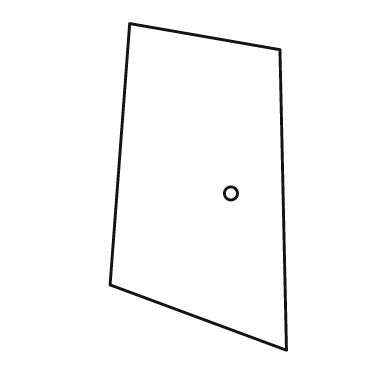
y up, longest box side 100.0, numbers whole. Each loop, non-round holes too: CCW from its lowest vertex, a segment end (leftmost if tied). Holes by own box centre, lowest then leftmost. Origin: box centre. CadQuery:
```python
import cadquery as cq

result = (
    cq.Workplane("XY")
    .moveTo(27.0, -50.0)
    .lineTo(25.0, 42.0)
    .lineTo(-21.0, 50.0)
    .lineTo(-27.0, -30.0)
    .close()
    .moveTo(10.0, -2.0)
    .circle(2.0)
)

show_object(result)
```